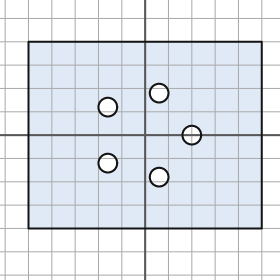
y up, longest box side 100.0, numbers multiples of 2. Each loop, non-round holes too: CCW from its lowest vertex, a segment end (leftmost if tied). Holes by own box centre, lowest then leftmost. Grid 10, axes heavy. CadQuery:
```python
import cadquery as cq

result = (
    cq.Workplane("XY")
    .moveTo(-50.0, -40.0)
    .lineTo(50.0, -40.0)
    .lineTo(50.0, 40.0)
    .lineTo(-50.0, 40.0)
    .close()
    .moveTo(6.0, -18.0)
    .circle(4.0)
    .moveTo(-16.0, -12.0)
    .circle(4.0)
    .moveTo(20.0, 0.0)
    .circle(4.0)
    .moveTo(-16.0, 12.0)
    .circle(4.0)
    .moveTo(6.0, 18.0)
    .circle(4.0)
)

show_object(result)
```